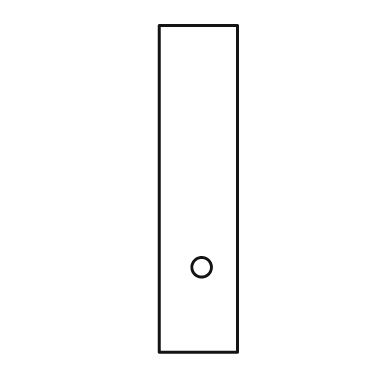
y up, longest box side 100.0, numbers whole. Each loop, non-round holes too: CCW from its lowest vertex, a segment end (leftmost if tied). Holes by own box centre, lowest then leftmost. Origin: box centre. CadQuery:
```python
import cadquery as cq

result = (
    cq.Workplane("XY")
    .moveTo(-12.0, -50.0)
    .lineTo(12.0, -50.0)
    .lineTo(12.0, 50.0)
    .lineTo(-12.0, 50.0)
    .close()
    .moveTo(1.0, -24.0)
    .circle(3.0)
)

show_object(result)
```